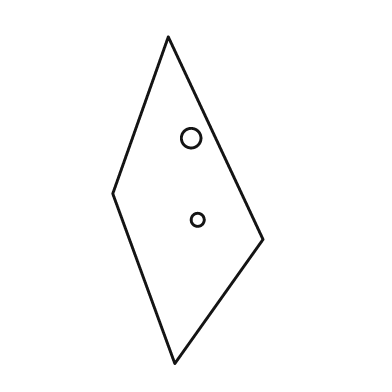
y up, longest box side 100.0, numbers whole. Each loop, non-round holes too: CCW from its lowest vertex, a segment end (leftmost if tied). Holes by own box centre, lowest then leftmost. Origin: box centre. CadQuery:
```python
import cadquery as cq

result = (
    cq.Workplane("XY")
    .moveTo(-4.0, -50.0)
    .lineTo(23.0, -12.0)
    .lineTo(-6.0, 50.0)
    .lineTo(-23.0, 2.0)
    .close()
    .moveTo(3.0, -6.0)
    .circle(2.0)
    .moveTo(1.0, 19.0)
    .circle(3.0)
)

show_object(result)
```